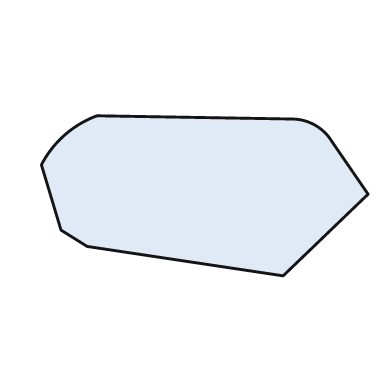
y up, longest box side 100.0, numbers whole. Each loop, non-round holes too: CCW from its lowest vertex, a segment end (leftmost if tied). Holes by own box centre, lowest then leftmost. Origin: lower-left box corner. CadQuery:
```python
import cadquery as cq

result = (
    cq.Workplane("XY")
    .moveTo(74.0, 0.0)
    .lineTo(100.0, 25.0)
    .lineTo(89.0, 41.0)
    .threePointArc((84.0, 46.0), (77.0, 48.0))
    .lineTo(17.0, 49.0)
    .threePointArc((7.0, 43.0), (0.0, 34.0))
    .lineTo(6.0, 14.0)
    .lineTo(14.0, 9.0)
    .close()
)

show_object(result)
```